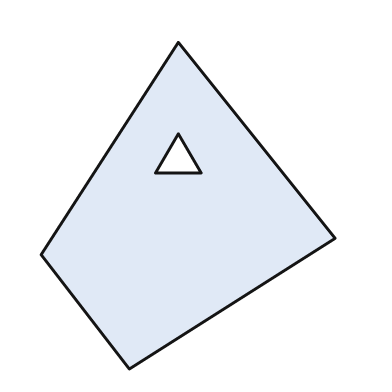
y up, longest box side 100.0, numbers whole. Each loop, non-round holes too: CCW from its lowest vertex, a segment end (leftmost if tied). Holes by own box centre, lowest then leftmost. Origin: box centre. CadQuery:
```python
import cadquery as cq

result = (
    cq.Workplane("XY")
    .moveTo(-18.0, -50.0)
    .lineTo(45.0, -10.0)
    .lineTo(-3.0, 50.0)
    .lineTo(-45.0, -15.0)
    .close()
    .moveTo(-10.0, 10.0)
    .lineTo(4.0, 10.0)
    .lineTo(-3.0, 22.0)
    .close()
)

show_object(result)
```